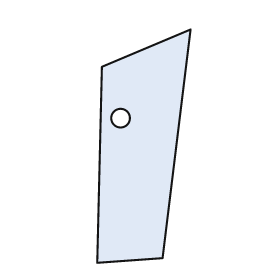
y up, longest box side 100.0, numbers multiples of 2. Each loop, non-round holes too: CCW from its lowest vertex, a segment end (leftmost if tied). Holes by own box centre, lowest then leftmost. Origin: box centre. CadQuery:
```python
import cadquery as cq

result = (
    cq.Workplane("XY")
    .moveTo(-20.0, -50.0)
    .lineTo(8.0, -48.0)
    .lineTo(20.0, 50.0)
    .lineTo(-18.0, 34.0)
    .close()
    .moveTo(-10.0, 12.0)
    .circle(4.0)
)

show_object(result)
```